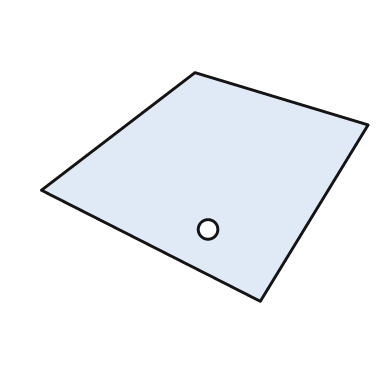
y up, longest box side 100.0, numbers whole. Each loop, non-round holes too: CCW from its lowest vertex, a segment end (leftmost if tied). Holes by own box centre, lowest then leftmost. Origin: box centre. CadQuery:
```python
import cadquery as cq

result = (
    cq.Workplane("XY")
    .moveTo(17.0, -35.0)
    .lineTo(50.0, 19.0)
    .lineTo(-3.0, 35.0)
    .lineTo(-50.0, -1.0)
    .close()
    .moveTo(1.0, -13.0)
    .circle(3.0)
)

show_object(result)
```